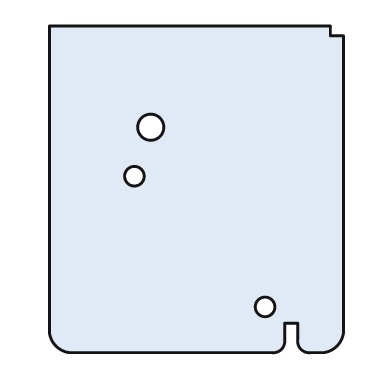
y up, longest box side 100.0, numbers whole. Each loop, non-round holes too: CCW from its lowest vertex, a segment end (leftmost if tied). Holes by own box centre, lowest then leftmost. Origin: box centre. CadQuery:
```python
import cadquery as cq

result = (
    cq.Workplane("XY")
    .moveTo(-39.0, -50.0)
    .lineTo(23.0, -50.0)
    .threePointArc((26.0, -49.0), (27.0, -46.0))
    .lineTo(27.0, -41.0)
    .lineTo(31.0, -41.0)
    .lineTo(31.0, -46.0)
    .threePointArc((32.0, -49.0), (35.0, -50.0))
    .lineTo(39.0, -50.0)
    .threePointArc((43.0, -48.0), (45.0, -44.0))
    .lineTo(45.0, 47.0)
    .lineTo(41.0, 47.0)
    .lineTo(41.0, 50.0)
    .lineTo(-45.0, 50.0)
    .lineTo(-45.0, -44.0)
    .threePointArc((-43.0, -48.0), (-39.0, -50.0))
    .close()
    .moveTo(21.0, -36.0)
    .circle(3.0)
    .moveTo(-19.0, 4.0)
    .circle(3.0)
    .moveTo(-14.0, 19.0)
    .circle(4.0)
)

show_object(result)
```